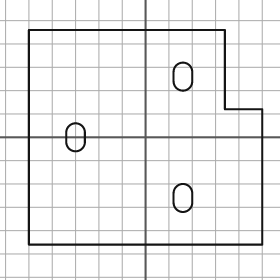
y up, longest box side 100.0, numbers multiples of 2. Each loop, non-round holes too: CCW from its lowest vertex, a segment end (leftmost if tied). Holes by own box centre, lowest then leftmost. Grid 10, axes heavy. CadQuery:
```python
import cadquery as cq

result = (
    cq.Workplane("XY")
    .moveTo(-50.0, -46.0)
    .lineTo(50.0, -46.0)
    .lineTo(50.0, 12.0)
    .lineTo(34.0, 12.0)
    .lineTo(34.0, 46.0)
    .lineTo(-50.0, 46.0)
    .close()
    .moveTo(12.0, -28.0)
    .threePointArc((16.0, -32.0), (20.0, -28.0))
    .lineTo(20.0, -24.0)
    .threePointArc((16.0, -20.0), (12.0, -24.0))
    .close()
    .moveTo(-34.0, -2.0)
    .threePointArc((-30.0, -6.0), (-26.0, -2.0))
    .lineTo(-26.0, 2.0)
    .threePointArc((-30.0, 6.0), (-34.0, 2.0))
    .close()
    .moveTo(12.0, 24.0)
    .threePointArc((16.0, 20.0), (20.0, 24.0))
    .lineTo(20.0, 28.0)
    .threePointArc((16.0, 32.0), (12.0, 28.0))
    .close()
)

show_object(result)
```